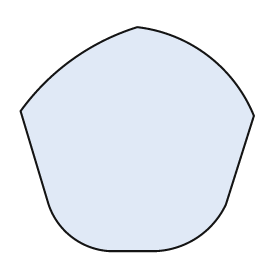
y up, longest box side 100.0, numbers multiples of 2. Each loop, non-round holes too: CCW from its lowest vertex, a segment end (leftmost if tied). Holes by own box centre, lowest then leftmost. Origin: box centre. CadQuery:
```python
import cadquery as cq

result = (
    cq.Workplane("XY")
    .moveTo(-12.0, -48.0)
    .lineTo(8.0, -48.0)
    .threePointArc((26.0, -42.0), (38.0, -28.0))
    .lineTo(50.0, 10.0)
    .threePointArc((30.0, 36.0), (0.0, 48.0))
    .threePointArc((-28.0, 34.0), (-50.0, 12.0))
    .lineTo(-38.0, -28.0)
    .threePointArc((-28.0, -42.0), (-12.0, -48.0))
    .close()
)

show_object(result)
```